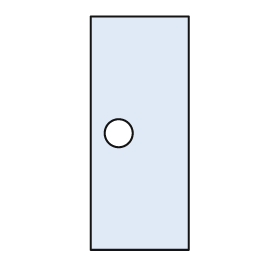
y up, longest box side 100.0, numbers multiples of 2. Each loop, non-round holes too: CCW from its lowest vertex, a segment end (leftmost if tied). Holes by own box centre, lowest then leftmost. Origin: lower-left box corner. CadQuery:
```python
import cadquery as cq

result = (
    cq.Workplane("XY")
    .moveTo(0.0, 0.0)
    .lineTo(42.0, 0.0)
    .lineTo(42.0, 100.0)
    .lineTo(0.0, 100.0)
    .close()
    .moveTo(12.0, 50.0)
    .circle(6.0)
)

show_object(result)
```